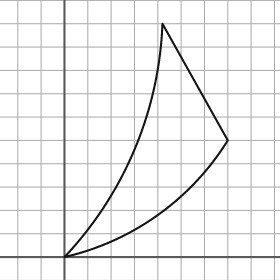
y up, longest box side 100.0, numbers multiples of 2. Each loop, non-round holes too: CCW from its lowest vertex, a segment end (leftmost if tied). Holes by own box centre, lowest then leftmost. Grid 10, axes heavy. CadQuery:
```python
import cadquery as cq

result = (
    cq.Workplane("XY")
    .moveTo(0.0, 0.0)
    .threePointArc((40.0, 18.0), (70.0, 50.0))
    .lineTo(42.0, 100.0)
    .threePointArc((30.0, 46.0), (0.0, 0.0))
    .close()
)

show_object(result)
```